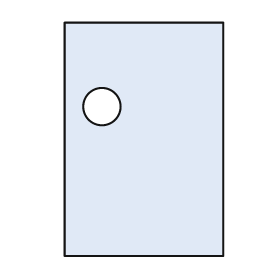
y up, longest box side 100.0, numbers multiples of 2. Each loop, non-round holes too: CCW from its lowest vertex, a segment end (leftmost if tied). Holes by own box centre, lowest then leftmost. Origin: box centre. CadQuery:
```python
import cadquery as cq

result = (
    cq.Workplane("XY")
    .moveTo(-34.0, -50.0)
    .lineTo(34.0, -50.0)
    .lineTo(34.0, 50.0)
    .lineTo(-34.0, 50.0)
    .close()
    .moveTo(-18.0, 14.0)
    .circle(8.0)
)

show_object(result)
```